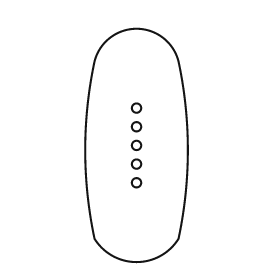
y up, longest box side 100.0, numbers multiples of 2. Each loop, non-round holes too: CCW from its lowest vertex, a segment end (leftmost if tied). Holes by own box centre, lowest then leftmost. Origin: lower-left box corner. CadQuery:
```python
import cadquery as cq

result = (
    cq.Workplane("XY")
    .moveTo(4.0, 10.0)
    .threePointArc((22.0, 0.0), (40.0, 10.0))
    .threePointArc((44.0, 48.0), (40.0, 86.0))
    .threePointArc((22.0, 100.0), (4.0, 86.0))
    .threePointArc((0.0, 48.0), (4.0, 10.0))
    .close()
    .moveTo(22.0, 34.0)
    .circle(2.0)
    .moveTo(22.0, 42.0)
    .circle(2.0)
    .moveTo(22.0, 50.0)
    .circle(2.0)
    .moveTo(22.0, 58.0)
    .circle(2.0)
    .moveTo(22.0, 66.0)
    .circle(2.0)
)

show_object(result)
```